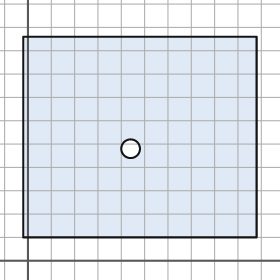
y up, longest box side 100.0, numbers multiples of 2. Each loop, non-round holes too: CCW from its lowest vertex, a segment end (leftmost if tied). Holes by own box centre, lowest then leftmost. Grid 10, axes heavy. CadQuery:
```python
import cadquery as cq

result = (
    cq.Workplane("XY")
    .moveTo(-2.0, 10.0)
    .lineTo(98.0, 10.0)
    .lineTo(98.0, 96.0)
    .lineTo(-2.0, 96.0)
    .close()
    .moveTo(44.0, 48.0)
    .circle(4.0)
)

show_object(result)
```